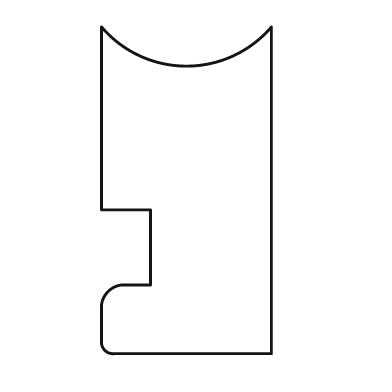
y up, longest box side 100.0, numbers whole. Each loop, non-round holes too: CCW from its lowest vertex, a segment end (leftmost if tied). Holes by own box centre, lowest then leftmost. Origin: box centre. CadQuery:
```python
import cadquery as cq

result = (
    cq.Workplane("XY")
    .moveTo(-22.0, -50.0)
    .lineTo(26.0, -50.0)
    .lineTo(26.0, 50.0)
    .threePointArc((0.0, 38.0), (-26.0, 50.0))
    .lineTo(-26.0, -6.0)
    .lineTo(-11.0, -6.0)
    .lineTo(-11.0, -29.0)
    .lineTo(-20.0, -29.0)
    .threePointArc((-24.0, -31.0), (-26.0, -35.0))
    .lineTo(-26.0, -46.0)
    .threePointArc((-25.0, -49.0), (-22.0, -50.0))
    .close()
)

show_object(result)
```